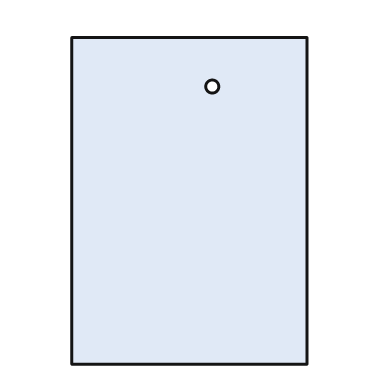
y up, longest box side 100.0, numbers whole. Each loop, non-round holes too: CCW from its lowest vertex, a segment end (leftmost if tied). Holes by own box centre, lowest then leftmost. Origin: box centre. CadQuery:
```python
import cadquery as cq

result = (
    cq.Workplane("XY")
    .moveTo(-36.0, -50.0)
    .lineTo(36.0, -50.0)
    .lineTo(36.0, 50.0)
    .lineTo(-36.0, 50.0)
    .close()
    .moveTo(7.0, 35.0)
    .circle(2.0)
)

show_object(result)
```